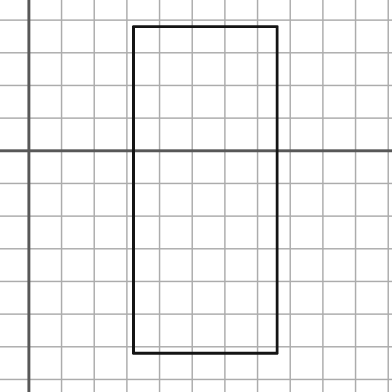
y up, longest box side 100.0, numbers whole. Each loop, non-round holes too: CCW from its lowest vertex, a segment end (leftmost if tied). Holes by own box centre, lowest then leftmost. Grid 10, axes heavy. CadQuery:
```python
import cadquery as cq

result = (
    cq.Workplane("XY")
    .moveTo(32.0, -62.0)
    .lineTo(76.0, -62.0)
    .lineTo(76.0, 38.0)
    .lineTo(32.0, 38.0)
    .close()
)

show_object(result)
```